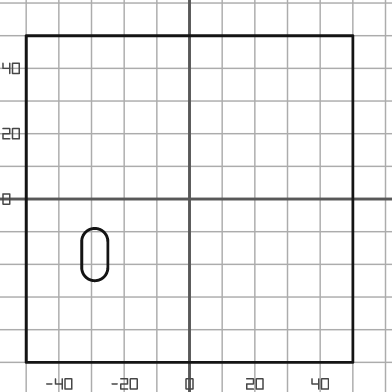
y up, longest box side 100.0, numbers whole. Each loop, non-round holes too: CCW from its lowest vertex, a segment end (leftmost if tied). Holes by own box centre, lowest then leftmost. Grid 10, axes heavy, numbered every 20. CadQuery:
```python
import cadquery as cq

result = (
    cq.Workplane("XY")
    .moveTo(-50.0, -50.0)
    .lineTo(50.0, -50.0)
    .lineTo(50.0, 50.0)
    .lineTo(-50.0, 50.0)
    .close()
    .moveTo(-33.0, -21.0)
    .threePointArc((-29.0, -25.0), (-25.0, -21.0))
    .lineTo(-25.0, -13.0)
    .threePointArc((-29.0, -9.0), (-33.0, -13.0))
    .close()
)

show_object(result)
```